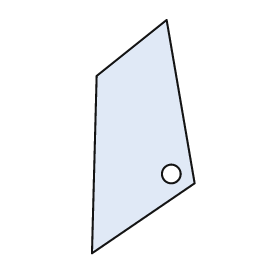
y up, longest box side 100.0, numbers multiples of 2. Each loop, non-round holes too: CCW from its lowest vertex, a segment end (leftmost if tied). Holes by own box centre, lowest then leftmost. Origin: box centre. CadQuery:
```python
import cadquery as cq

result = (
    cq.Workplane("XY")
    .moveTo(-22.0, -50.0)
    .lineTo(22.0, -20.0)
    .lineTo(10.0, 50.0)
    .lineTo(-20.0, 26.0)
    .close()
    .moveTo(12.0, -16.0)
    .circle(4.0)
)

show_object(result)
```